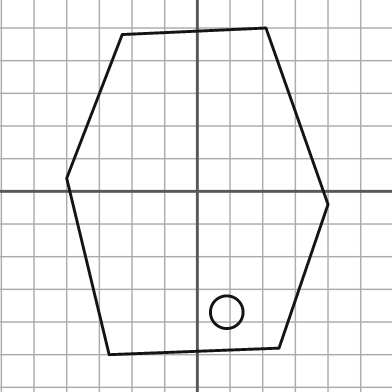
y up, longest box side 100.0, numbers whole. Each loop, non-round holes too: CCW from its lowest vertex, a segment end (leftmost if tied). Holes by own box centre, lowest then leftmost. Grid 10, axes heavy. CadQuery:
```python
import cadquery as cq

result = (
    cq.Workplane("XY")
    .moveTo(-27.0, -50.0)
    .lineTo(25.0, -48.0)
    .lineTo(40.0, -4.0)
    .lineTo(21.0, 50.0)
    .lineTo(-23.0, 48.0)
    .lineTo(-40.0, 4.0)
    .close()
    .moveTo(9.0, -37.0)
    .circle(5.0)
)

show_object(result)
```